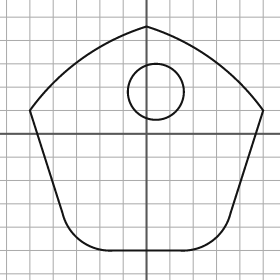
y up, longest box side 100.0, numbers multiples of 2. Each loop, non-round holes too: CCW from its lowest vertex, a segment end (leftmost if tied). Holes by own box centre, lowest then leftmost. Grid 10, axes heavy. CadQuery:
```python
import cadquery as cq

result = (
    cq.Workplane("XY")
    .moveTo(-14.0, -50.0)
    .lineTo(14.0, -50.0)
    .threePointArc((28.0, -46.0), (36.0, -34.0))
    .lineTo(50.0, 10.0)
    .threePointArc((28.0, 32.0), (0.0, 46.0))
    .threePointArc((-28.0, 32.0), (-50.0, 10.0))
    .lineTo(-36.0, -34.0)
    .threePointArc((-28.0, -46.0), (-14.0, -50.0))
    .close()
    .moveTo(4.0, 18.0)
    .circle(12.0)
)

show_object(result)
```